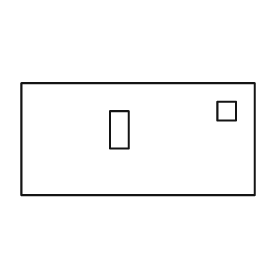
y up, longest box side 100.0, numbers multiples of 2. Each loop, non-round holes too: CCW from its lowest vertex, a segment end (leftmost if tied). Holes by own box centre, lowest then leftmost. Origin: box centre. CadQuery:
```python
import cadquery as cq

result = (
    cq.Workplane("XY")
    .moveTo(-50.0, -24.0)
    .lineTo(50.0, -24.0)
    .lineTo(50.0, 24.0)
    .lineTo(-50.0, 24.0)
    .close()
    .moveTo(-12.0, -4.0)
    .lineTo(-4.0, -4.0)
    .lineTo(-4.0, 12.0)
    .lineTo(-12.0, 12.0)
    .close()
    .moveTo(34.0, 8.0)
    .lineTo(42.0, 8.0)
    .lineTo(42.0, 16.0)
    .lineTo(34.0, 16.0)
    .close()
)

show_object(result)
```